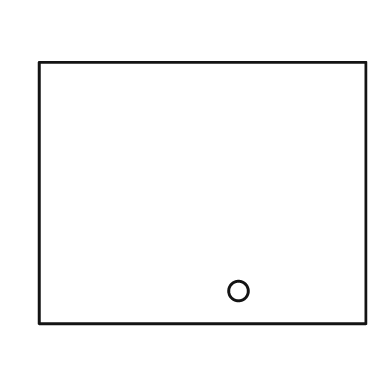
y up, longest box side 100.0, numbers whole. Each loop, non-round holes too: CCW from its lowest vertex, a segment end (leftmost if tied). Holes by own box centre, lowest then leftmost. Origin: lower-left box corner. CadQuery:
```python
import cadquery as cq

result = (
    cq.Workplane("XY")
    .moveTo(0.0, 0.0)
    .lineTo(100.0, 0.0)
    .lineTo(100.0, 80.0)
    .lineTo(0.0, 80.0)
    .close()
    .moveTo(61.0, 10.0)
    .circle(3.0)
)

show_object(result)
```